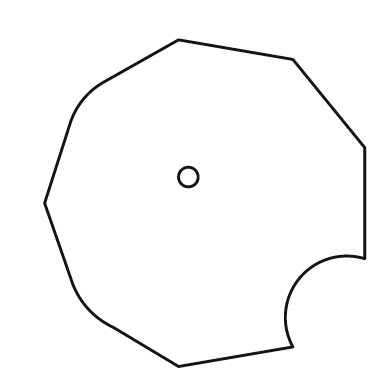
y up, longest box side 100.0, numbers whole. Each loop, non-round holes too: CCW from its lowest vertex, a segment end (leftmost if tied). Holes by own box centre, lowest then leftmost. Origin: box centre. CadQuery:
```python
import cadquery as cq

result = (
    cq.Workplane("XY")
    .moveTo(-8.0, -50.0)
    .lineTo(27.0, -44.0)
    .threePointArc((29.0, -23.0), (49.0, -17.0))
    .lineTo(49.0, 17.0)
    .lineTo(27.0, 44.0)
    .lineTo(-8.0, 50.0)
    .lineTo(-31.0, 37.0)
    .threePointArc((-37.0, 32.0), (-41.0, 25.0))
    .lineTo(-49.0, 0.0)
    .lineTo(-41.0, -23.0)
    .threePointArc((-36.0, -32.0), (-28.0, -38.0))
    .close()
    .moveTo(-5.0, 8.0)
    .circle(3.0)
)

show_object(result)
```